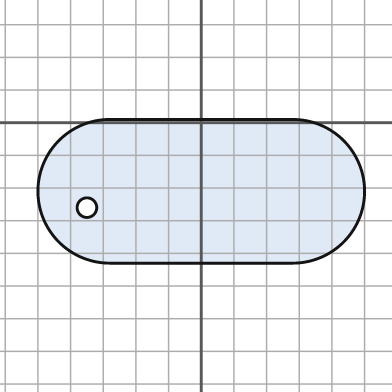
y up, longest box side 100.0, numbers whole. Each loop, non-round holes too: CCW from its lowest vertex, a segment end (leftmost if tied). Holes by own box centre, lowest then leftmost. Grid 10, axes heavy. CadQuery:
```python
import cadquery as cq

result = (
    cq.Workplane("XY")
    .moveTo(-28.0, -43.0)
    .lineTo(28.0, -43.0)
    .threePointArc((50.0, -21.0), (28.0, 1.0))
    .lineTo(-28.0, 1.0)
    .threePointArc((-50.0, -21.0), (-28.0, -43.0))
    .close()
    .moveTo(-35.0, -26.0)
    .circle(3.0)
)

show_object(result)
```